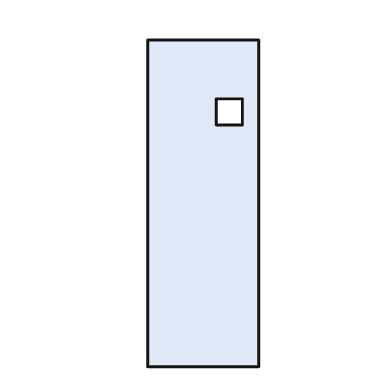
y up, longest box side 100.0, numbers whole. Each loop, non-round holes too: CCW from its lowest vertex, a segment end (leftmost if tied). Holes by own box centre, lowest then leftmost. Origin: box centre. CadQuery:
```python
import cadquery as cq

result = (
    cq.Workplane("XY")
    .moveTo(-17.0, -50.0)
    .lineTo(17.0, -50.0)
    .lineTo(17.0, 50.0)
    .lineTo(-17.0, 50.0)
    .close()
    .moveTo(4.0, 24.0)
    .lineTo(12.0, 24.0)
    .lineTo(12.0, 32.0)
    .lineTo(4.0, 32.0)
    .close()
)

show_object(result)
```